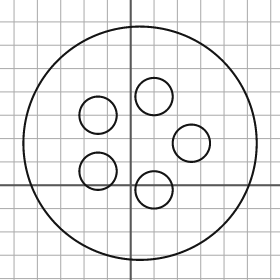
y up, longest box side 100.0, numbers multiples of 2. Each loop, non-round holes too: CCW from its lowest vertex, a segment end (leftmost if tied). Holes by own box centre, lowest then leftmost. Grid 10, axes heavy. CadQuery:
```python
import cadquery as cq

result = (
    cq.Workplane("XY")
    .moveTo(4.0, 18.0)
    .circle(50.0)
    .moveTo(10.0, -2.0)
    .circle(8.0)
    .moveTo(-14.0, 6.0)
    .circle(8.0)
    .moveTo(26.0, 18.0)
    .circle(8.0)
    .moveTo(-14.0, 30.0)
    .circle(8.0)
    .moveTo(10.0, 38.0)
    .circle(8.0)
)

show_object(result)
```